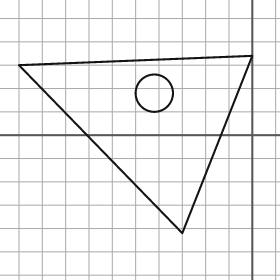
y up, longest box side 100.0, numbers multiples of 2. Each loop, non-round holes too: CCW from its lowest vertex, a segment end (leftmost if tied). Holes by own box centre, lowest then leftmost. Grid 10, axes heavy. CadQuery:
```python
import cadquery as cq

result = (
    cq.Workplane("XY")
    .moveTo(-30.0, -42.0)
    .lineTo(0.0, 34.0)
    .lineTo(-100.0, 30.0)
    .close()
    .moveTo(-42.0, 18.0)
    .circle(8.0)
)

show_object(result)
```